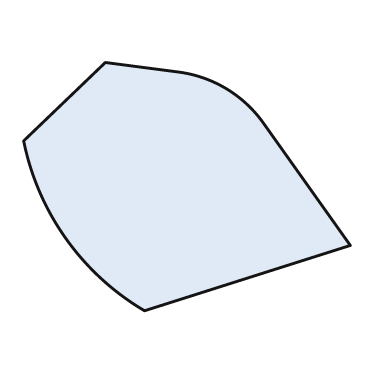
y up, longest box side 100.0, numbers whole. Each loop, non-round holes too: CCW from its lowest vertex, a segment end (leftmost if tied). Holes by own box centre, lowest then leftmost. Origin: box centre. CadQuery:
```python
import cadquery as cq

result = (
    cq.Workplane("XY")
    .moveTo(-13.0, -38.0)
    .lineTo(50.0, -18.0)
    .lineTo(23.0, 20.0)
    .threePointArc((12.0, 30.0), (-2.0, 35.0))
    .lineTo(-25.0, 38.0)
    .lineTo(-50.0, 14.0)
    .threePointArc((-37.0, -16.0), (-13.0, -38.0))
    .close()
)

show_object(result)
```